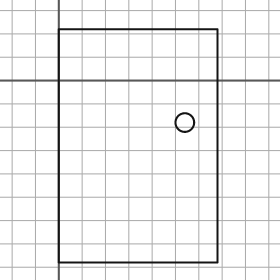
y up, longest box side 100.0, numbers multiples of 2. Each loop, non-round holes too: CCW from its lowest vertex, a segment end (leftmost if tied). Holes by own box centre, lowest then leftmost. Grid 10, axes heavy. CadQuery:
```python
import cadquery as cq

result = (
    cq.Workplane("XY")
    .moveTo(0.0, -78.0)
    .lineTo(68.0, -78.0)
    .lineTo(68.0, 22.0)
    .lineTo(0.0, 22.0)
    .close()
    .moveTo(54.0, -18.0)
    .circle(4.0)
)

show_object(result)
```